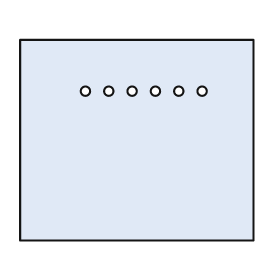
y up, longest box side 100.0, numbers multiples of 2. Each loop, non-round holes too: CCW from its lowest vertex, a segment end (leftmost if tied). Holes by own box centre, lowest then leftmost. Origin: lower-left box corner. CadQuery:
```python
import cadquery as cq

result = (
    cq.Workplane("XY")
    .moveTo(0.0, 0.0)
    .lineTo(100.0, 0.0)
    .lineTo(100.0, 86.0)
    .lineTo(0.0, 86.0)
    .close()
    .moveTo(28.0, 64.0)
    .circle(2.0)
    .moveTo(38.0, 64.0)
    .circle(2.0)
    .moveTo(48.0, 64.0)
    .circle(2.0)
    .moveTo(58.0, 64.0)
    .circle(2.0)
    .moveTo(68.0, 64.0)
    .circle(2.0)
    .moveTo(78.0, 64.0)
    .circle(2.0)
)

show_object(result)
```